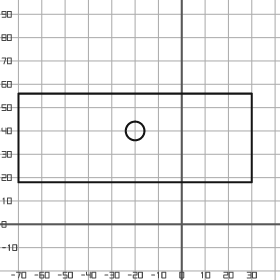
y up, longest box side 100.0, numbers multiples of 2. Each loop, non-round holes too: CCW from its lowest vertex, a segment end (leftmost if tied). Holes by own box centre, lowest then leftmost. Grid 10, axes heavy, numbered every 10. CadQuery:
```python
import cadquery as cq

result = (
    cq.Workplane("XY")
    .moveTo(-70.0, 18.0)
    .lineTo(30.0, 18.0)
    .lineTo(30.0, 56.0)
    .lineTo(-70.0, 56.0)
    .close()
    .moveTo(-20.0, 40.0)
    .circle(4.0)
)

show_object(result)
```